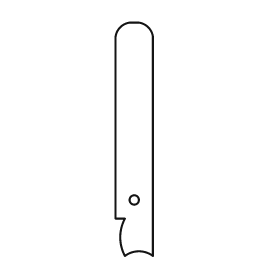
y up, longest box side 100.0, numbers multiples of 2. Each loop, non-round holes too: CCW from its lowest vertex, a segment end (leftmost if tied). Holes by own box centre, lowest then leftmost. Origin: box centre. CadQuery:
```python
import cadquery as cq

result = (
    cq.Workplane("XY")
    .moveTo(-4.0, -50.0)
    .threePointArc((2.0, -48.0), (8.0, -50.0))
    .lineTo(8.0, 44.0)
    .threePointArc((6.0, 48.0), (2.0, 50.0))
    .lineTo(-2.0, 50.0)
    .threePointArc((-6.0, 48.0), (-8.0, 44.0))
    .lineTo(-8.0, -34.0)
    .lineTo(-4.0, -34.0)
    .threePointArc((-6.0, -42.0), (-4.0, -50.0))
    .close()
    .moveTo(0.0, -26.0)
    .circle(2.0)
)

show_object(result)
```